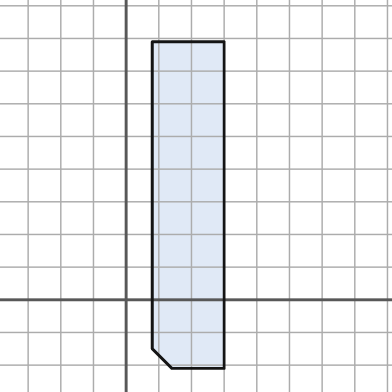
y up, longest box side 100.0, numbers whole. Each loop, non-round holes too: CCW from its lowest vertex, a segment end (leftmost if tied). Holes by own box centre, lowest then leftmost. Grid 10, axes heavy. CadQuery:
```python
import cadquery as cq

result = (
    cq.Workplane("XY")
    .moveTo(14.0, -21.0)
    .lineTo(30.0, -21.0)
    .lineTo(30.0, 79.0)
    .lineTo(8.0, 79.0)
    .lineTo(8.0, -15.0)
    .close()
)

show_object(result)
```